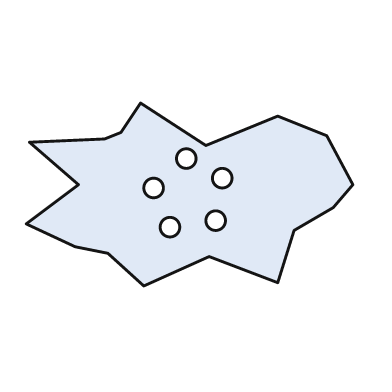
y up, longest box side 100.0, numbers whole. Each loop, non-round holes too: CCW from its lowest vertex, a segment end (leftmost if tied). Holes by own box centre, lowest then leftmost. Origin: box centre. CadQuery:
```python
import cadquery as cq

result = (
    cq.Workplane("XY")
    .moveTo(-14.0, -28.0)
    .lineTo(6.0, -19.0)
    .lineTo(27.0, -27.0)
    .lineTo(32.0, -11.0)
    .lineTo(44.0, -4.0)
    .lineTo(50.0, 3.0)
    .lineTo(42.0, 18.0)
    .lineTo(27.0, 24.0)
    .lineTo(5.0, 15.0)
    .lineTo(-15.0, 28.0)
    .lineTo(-21.0, 19.0)
    .lineTo(-26.0, 17.0)
    .lineTo(-49.0, 16.0)
    .lineTo(-34.0, 3.0)
    .lineTo(-50.0, -9.0)
    .lineTo(-35.0, -16.0)
    .lineTo(-25.0, -18.0)
    .close()
    .moveTo(-6.0, -10.0)
    .circle(3.0)
    .moveTo(8.0, -8.0)
    .circle(3.0)
    .moveTo(-11.0, 2.0)
    .circle(3.0)
    .moveTo(10.0, 5.0)
    .circle(3.0)
    .moveTo(-1.0, 11.0)
    .circle(3.0)
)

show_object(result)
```